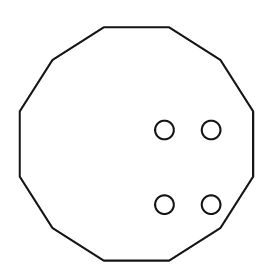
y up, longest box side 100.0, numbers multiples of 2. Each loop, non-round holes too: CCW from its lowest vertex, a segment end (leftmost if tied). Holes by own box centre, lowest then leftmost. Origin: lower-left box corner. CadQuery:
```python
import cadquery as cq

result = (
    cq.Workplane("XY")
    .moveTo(36.0, 0.0)
    .lineTo(64.0, 0.0)
    .lineTo(86.0, 14.0)
    .lineTo(100.0, 36.0)
    .lineTo(100.0, 64.0)
    .lineTo(86.0, 86.0)
    .lineTo(64.0, 100.0)
    .lineTo(36.0, 100.0)
    .lineTo(14.0, 86.0)
    .lineTo(0.0, 64.0)
    .lineTo(0.0, 36.0)
    .lineTo(14.0, 14.0)
    .close()
    .moveTo(62.0, 24.0)
    .circle(4.0)
    .moveTo(82.0, 24.0)
    .circle(4.0)
    .moveTo(62.0, 56.0)
    .circle(4.0)
    .moveTo(82.0, 56.0)
    .circle(4.0)
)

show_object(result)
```